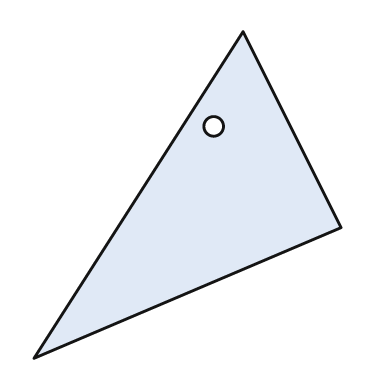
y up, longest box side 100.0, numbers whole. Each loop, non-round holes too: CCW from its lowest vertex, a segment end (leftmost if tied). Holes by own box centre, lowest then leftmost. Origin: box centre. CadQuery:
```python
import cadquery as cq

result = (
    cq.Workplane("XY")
    .moveTo(-47.0, -50.0)
    .lineTo(47.0, -10.0)
    .lineTo(17.0, 50.0)
    .close()
    .moveTo(8.0, 21.0)
    .circle(3.0)
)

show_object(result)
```